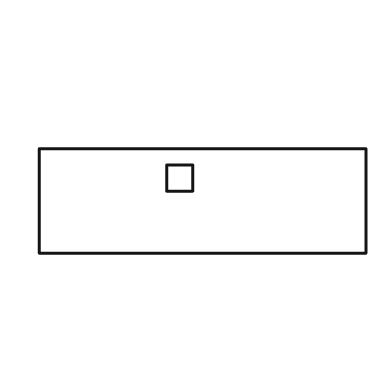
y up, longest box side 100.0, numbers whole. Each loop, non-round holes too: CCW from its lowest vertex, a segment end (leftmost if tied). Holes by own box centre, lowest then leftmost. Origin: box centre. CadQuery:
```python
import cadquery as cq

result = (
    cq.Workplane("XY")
    .moveTo(-50.0, -16.0)
    .lineTo(50.0, -16.0)
    .lineTo(50.0, 16.0)
    .lineTo(-50.0, 16.0)
    .close()
    .moveTo(-11.0, 3.0)
    .lineTo(-3.0, 3.0)
    .lineTo(-3.0, 11.0)
    .lineTo(-11.0, 11.0)
    .close()
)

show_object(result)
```